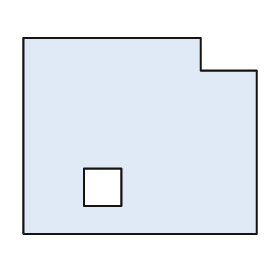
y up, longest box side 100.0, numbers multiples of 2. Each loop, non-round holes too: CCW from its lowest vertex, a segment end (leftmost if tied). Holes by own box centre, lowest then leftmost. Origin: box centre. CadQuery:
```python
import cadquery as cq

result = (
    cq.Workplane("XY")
    .moveTo(-50.0, -42.0)
    .lineTo(50.0, -42.0)
    .lineTo(50.0, 28.0)
    .lineTo(26.0, 28.0)
    .lineTo(26.0, 42.0)
    .lineTo(-50.0, 42.0)
    .close()
    .moveTo(-24.0, -30.0)
    .lineTo(-8.0, -30.0)
    .lineTo(-8.0, -14.0)
    .lineTo(-24.0, -14.0)
    .close()
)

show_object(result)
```